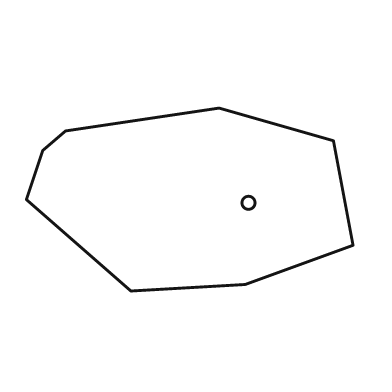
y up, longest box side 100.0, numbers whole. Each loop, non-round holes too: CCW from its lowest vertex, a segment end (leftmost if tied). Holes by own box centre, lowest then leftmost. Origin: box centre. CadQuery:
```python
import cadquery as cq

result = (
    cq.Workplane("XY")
    .moveTo(-18.0, -28.0)
    .lineTo(17.0, -26.0)
    .lineTo(50.0, -14.0)
    .lineTo(44.0, 18.0)
    .lineTo(9.0, 28.0)
    .lineTo(-38.0, 21.0)
    .lineTo(-45.0, 15.0)
    .lineTo(-50.0, 0.0)
    .close()
    .moveTo(18.0, -1.0)
    .circle(2.0)
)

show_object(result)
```